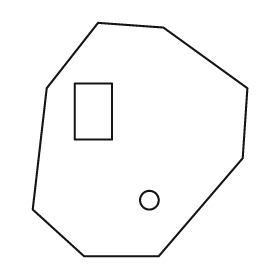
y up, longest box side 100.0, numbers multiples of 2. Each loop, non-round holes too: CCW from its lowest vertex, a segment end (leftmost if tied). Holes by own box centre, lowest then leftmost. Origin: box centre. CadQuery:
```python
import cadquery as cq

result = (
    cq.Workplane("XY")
    .moveTo(-24.0, -50.0)
    .lineTo(8.0, -50.0)
    .lineTo(44.0, -8.0)
    .lineTo(46.0, 22.0)
    .lineTo(10.0, 48.0)
    .lineTo(-18.0, 50.0)
    .lineTo(-40.0, 22.0)
    .lineTo(-46.0, -30.0)
    .close()
    .moveTo(4.0, -26.0)
    .circle(4.0)
    .moveTo(-28.0, 0.0)
    .lineTo(-12.0, 0.0)
    .lineTo(-12.0, 24.0)
    .lineTo(-28.0, 24.0)
    .close()
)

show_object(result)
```